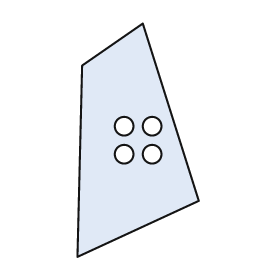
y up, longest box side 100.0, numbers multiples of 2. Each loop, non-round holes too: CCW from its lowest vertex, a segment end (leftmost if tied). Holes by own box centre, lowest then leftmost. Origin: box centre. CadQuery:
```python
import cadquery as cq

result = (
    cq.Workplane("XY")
    .moveTo(-26.0, -50.0)
    .lineTo(26.0, -26.0)
    .lineTo(2.0, 50.0)
    .lineTo(-24.0, 32.0)
    .close()
    .moveTo(-6.0, -6.0)
    .circle(4.0)
    .moveTo(6.0, -6.0)
    .circle(4.0)
    .moveTo(-6.0, 6.0)
    .circle(4.0)
    .moveTo(6.0, 6.0)
    .circle(4.0)
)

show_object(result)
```